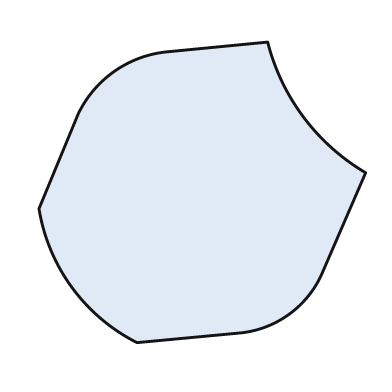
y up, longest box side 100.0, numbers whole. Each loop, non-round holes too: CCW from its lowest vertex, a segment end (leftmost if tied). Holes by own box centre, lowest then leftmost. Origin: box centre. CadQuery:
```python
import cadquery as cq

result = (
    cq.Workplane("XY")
    .moveTo(-20.0, -46.0)
    .lineTo(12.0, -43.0)
    .threePointArc((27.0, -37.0), (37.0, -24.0))
    .lineTo(50.0, 6.0)
    .threePointArc((31.0, 23.0), (20.0, 46.0))
    .lineTo(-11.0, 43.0)
    .threePointArc((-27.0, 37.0), (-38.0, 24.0))
    .lineTo(-50.0, -5.0)
    .threePointArc((-40.0, -29.0), (-20.0, -46.0))
    .close()
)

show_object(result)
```